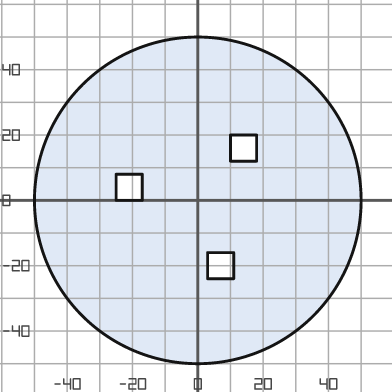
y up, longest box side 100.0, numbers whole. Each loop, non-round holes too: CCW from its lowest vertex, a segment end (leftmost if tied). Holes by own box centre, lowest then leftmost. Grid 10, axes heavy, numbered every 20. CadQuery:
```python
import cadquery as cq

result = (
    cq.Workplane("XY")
    .moveTo(0.0, 0.0)
    .circle(50.0)
    .moveTo(3.0, -24.0)
    .lineTo(11.0, -24.0)
    .lineTo(11.0, -16.0)
    .lineTo(3.0, -16.0)
    .close()
    .moveTo(-25.0, 0.0)
    .lineTo(-17.0, 0.0)
    .lineTo(-17.0, 8.0)
    .lineTo(-25.0, 8.0)
    .close()
    .moveTo(10.0, 12.0)
    .lineTo(18.0, 12.0)
    .lineTo(18.0, 20.0)
    .lineTo(10.0, 20.0)
    .close()
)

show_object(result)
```